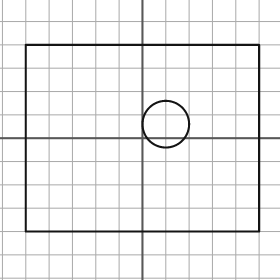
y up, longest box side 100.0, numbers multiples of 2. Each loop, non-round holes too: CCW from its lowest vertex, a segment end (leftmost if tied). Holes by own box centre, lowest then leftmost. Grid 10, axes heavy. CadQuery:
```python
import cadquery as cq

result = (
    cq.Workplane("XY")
    .moveTo(-50.0, -40.0)
    .lineTo(50.0, -40.0)
    .lineTo(50.0, 40.0)
    .lineTo(-50.0, 40.0)
    .close()
    .moveTo(10.0, 6.0)
    .circle(10.0)
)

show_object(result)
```